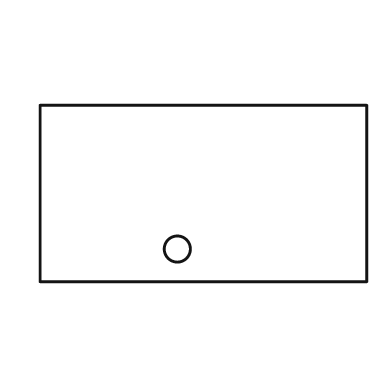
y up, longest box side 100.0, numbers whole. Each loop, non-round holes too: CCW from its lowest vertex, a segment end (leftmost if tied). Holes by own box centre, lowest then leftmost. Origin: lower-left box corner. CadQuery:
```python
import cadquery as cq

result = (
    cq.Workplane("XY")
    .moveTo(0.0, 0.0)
    .lineTo(100.0, 0.0)
    .lineTo(100.0, 54.0)
    .lineTo(0.0, 54.0)
    .close()
    .moveTo(42.0, 10.0)
    .circle(4.0)
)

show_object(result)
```